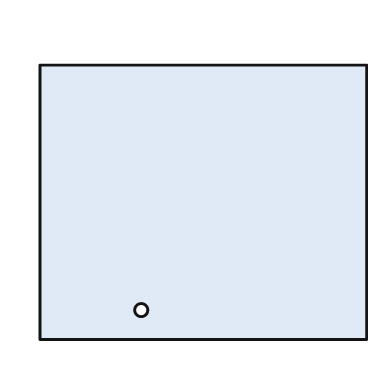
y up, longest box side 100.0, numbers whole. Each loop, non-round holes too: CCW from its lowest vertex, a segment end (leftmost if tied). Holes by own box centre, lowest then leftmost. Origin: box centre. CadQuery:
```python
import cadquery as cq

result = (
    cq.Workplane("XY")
    .moveTo(-50.0, -42.0)
    .lineTo(50.0, -42.0)
    .lineTo(50.0, 42.0)
    .lineTo(-50.0, 42.0)
    .close()
    .moveTo(-19.0, -33.0)
    .circle(2.0)
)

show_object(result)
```